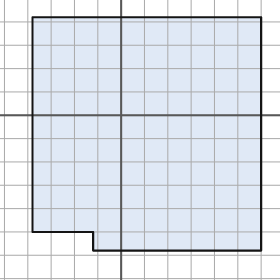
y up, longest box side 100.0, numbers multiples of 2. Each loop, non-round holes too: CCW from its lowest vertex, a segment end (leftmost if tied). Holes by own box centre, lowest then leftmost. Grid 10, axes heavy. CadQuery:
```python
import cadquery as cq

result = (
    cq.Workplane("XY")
    .moveTo(-12.0, -58.0)
    .lineTo(60.0, -58.0)
    .lineTo(60.0, 42.0)
    .lineTo(-38.0, 42.0)
    .lineTo(-38.0, -50.0)
    .lineTo(-12.0, -50.0)
    .close()
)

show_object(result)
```